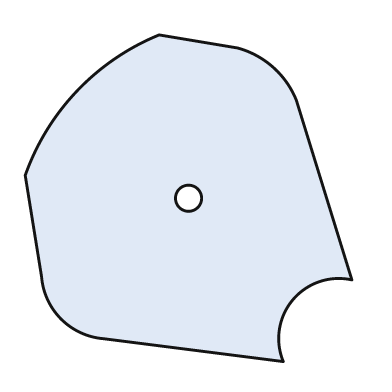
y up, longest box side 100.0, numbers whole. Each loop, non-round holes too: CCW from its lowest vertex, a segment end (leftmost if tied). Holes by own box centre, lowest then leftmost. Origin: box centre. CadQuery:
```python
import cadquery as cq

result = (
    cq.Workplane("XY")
    .moveTo(29.0, -50.0)
    .threePointArc((32.0, -31.0), (50.0, -25.0))
    .lineTo(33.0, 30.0)
    .threePointArc((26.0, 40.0), (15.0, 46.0))
    .lineTo(-9.0, 50.0)
    .threePointArc((-34.0, 33.0), (-50.0, 7.0))
    .lineTo(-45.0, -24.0)
    .threePointArc((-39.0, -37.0), (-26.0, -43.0))
    .close()
    .moveTo(0.0, 0.0)
    .circle(4.0)
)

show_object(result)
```